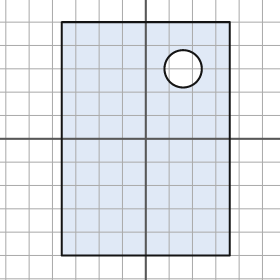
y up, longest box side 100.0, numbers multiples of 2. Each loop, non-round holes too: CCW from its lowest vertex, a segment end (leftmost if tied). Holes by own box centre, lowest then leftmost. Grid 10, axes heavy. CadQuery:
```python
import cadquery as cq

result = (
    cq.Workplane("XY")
    .moveTo(-36.0, -50.0)
    .lineTo(36.0, -50.0)
    .lineTo(36.0, 50.0)
    .lineTo(-36.0, 50.0)
    .close()
    .moveTo(16.0, 30.0)
    .circle(8.0)
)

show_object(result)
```